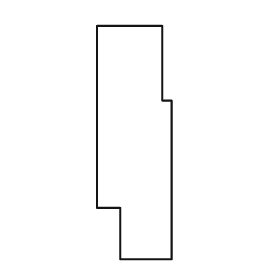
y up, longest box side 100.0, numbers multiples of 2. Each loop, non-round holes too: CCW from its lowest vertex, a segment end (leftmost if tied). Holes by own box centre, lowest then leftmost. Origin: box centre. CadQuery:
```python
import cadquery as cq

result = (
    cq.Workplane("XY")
    .moveTo(-6.0, -50.0)
    .lineTo(16.0, -50.0)
    .lineTo(16.0, 18.0)
    .lineTo(12.0, 18.0)
    .lineTo(12.0, 50.0)
    .lineTo(-16.0, 50.0)
    .lineTo(-16.0, -28.0)
    .lineTo(-6.0, -28.0)
    .close()
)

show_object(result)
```